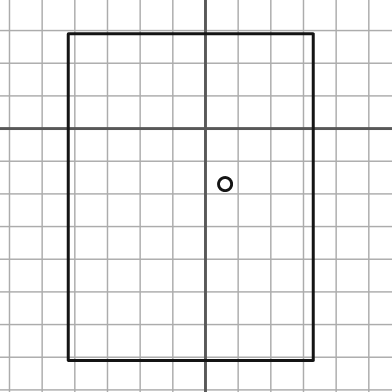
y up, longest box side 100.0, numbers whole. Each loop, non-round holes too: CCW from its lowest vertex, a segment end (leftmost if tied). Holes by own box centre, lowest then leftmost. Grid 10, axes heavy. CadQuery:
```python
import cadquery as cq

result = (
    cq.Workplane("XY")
    .moveTo(-42.0, -71.0)
    .lineTo(33.0, -71.0)
    .lineTo(33.0, 29.0)
    .lineTo(-42.0, 29.0)
    .close()
    .moveTo(6.0, -17.0)
    .circle(2.0)
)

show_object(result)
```